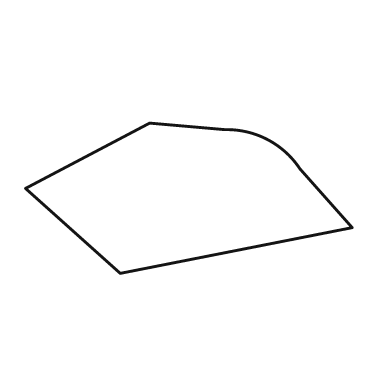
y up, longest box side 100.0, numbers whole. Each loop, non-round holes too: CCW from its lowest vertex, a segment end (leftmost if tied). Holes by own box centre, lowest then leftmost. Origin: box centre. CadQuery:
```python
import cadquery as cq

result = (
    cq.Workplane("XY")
    .moveTo(-21.0, -23.0)
    .lineTo(50.0, -9.0)
    .lineTo(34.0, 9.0)
    .threePointArc((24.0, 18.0), (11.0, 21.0))
    .lineTo(-12.0, 23.0)
    .lineTo(-50.0, 3.0)
    .close()
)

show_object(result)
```